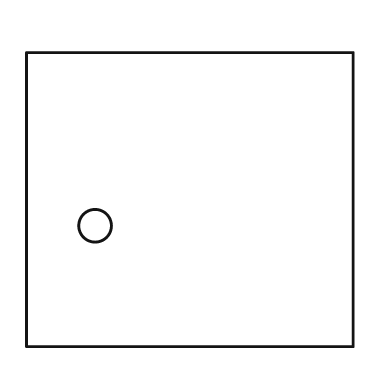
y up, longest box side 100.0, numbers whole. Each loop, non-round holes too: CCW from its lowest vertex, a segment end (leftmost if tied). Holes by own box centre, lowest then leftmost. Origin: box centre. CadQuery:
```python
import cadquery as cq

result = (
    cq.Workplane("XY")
    .moveTo(-50.0, -45.0)
    .lineTo(50.0, -45.0)
    .lineTo(50.0, 45.0)
    .lineTo(-50.0, 45.0)
    .close()
    .moveTo(-29.0, -8.0)
    .circle(5.0)
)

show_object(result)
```